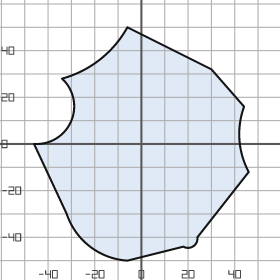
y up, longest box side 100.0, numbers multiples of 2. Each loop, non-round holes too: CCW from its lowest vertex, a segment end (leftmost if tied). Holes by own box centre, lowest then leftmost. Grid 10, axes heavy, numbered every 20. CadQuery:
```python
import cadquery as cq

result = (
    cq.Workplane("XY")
    .moveTo(-6.0, -50.0)
    .lineTo(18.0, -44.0)
    .threePointArc((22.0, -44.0), (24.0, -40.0))
    .lineTo(46.0, -12.0)
    .threePointArc((42.0, 2.0), (44.0, 16.0))
    .lineTo(30.0, 32.0)
    .lineTo(-6.0, 50.0)
    .threePointArc((-18.0, 36.0), (-34.0, 28.0))
    .threePointArc((-30.0, 10.0), (-46.0, 0.0))
    .lineTo(-32.0, -30.0)
    .threePointArc((-22.0, -44.0), (-6.0, -50.0))
    .close()
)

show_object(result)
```